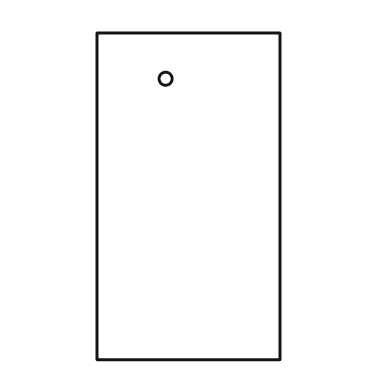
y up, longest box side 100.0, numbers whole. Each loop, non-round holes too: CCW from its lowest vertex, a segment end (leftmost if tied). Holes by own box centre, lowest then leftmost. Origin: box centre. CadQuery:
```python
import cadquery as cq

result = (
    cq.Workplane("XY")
    .moveTo(-28.0, -50.0)
    .lineTo(28.0, -50.0)
    .lineTo(28.0, 50.0)
    .lineTo(-28.0, 50.0)
    .close()
    .moveTo(-7.0, 36.0)
    .circle(2.0)
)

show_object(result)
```